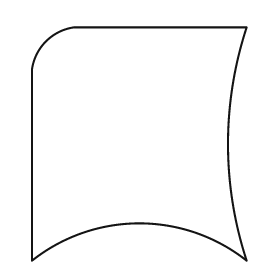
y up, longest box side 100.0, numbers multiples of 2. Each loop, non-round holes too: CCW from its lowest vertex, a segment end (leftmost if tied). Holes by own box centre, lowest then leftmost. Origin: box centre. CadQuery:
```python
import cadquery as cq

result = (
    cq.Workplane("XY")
    .moveTo(-46.0, -50.0)
    .threePointArc((0.0, -34.0), (46.0, -50.0))
    .threePointArc((38.0, 0.0), (46.0, 50.0))
    .lineTo(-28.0, 50.0)
    .threePointArc((-40.0, 44.0), (-46.0, 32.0))
    .close()
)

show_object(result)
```